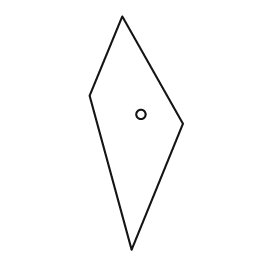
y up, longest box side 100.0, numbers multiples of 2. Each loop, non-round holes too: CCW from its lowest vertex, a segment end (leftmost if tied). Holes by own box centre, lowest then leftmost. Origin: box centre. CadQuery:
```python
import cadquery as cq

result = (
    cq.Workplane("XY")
    .moveTo(-2.0, -50.0)
    .lineTo(20.0, 4.0)
    .lineTo(-6.0, 50.0)
    .lineTo(-20.0, 16.0)
    .close()
    .moveTo(2.0, 8.0)
    .circle(2.0)
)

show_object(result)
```